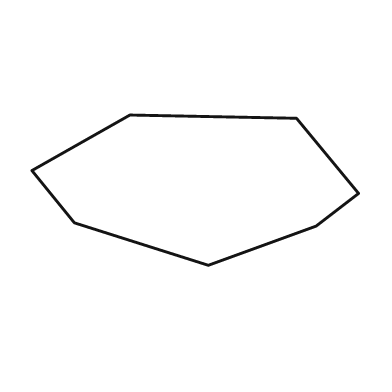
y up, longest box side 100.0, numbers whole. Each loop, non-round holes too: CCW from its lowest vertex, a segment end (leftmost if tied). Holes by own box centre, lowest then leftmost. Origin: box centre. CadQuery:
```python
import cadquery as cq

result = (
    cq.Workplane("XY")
    .moveTo(4.0, -23.0)
    .lineTo(37.0, -11.0)
    .lineTo(50.0, -1.0)
    .lineTo(31.0, 22.0)
    .lineTo(-20.0, 23.0)
    .lineTo(-50.0, 6.0)
    .lineTo(-37.0, -10.0)
    .close()
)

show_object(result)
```